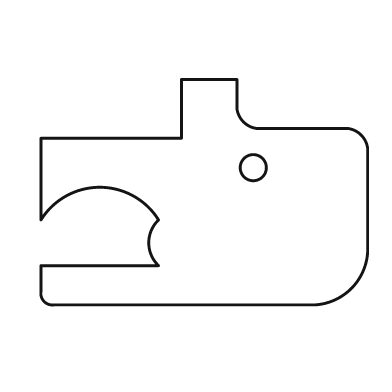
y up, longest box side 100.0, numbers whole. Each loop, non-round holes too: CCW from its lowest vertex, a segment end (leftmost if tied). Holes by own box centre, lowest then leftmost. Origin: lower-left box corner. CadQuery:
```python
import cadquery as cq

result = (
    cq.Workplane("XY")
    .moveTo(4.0, 0.0)
    .lineTo(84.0, 0.0)
    .threePointArc((95.0, 5.0), (100.0, 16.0))
    .lineTo(100.0, 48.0)
    .threePointArc((98.0, 52.0), (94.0, 54.0))
    .lineTo(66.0, 54.0)
    .threePointArc((62.0, 56.0), (60.0, 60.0))
    .lineTo(60.0, 69.0)
    .lineTo(43.0, 69.0)
    .lineTo(43.0, 51.0)
    .lineTo(0.0, 51.0)
    .lineTo(0.0, 26.0)
    .threePointArc((18.0, 36.0), (36.0, 26.0))
    .threePointArc((33.0, 19.0), (36.0, 12.0))
    .lineTo(0.0, 12.0)
    .lineTo(0.0, 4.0)
    .threePointArc((1.0, 1.0), (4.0, 0.0))
    .close()
    .moveTo(65.0, 42.0)
    .circle(4.0)
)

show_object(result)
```